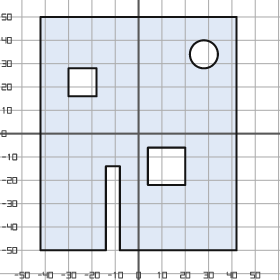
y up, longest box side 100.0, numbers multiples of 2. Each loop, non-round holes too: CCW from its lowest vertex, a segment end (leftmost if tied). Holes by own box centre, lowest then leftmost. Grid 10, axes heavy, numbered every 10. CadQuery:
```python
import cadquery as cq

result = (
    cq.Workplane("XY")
    .moveTo(-42.0, -50.0)
    .lineTo(-14.0, -50.0)
    .lineTo(-14.0, -14.0)
    .lineTo(-8.0, -14.0)
    .lineTo(-8.0, -50.0)
    .lineTo(42.0, -50.0)
    .lineTo(42.0, 50.0)
    .lineTo(-42.0, 50.0)
    .close()
    .moveTo(4.0, -22.0)
    .lineTo(20.0, -22.0)
    .lineTo(20.0, -6.0)
    .lineTo(4.0, -6.0)
    .close()
    .moveTo(-30.0, 16.0)
    .lineTo(-18.0, 16.0)
    .lineTo(-18.0, 28.0)
    .lineTo(-30.0, 28.0)
    .close()
    .moveTo(28.0, 34.0)
    .circle(6.0)
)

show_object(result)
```